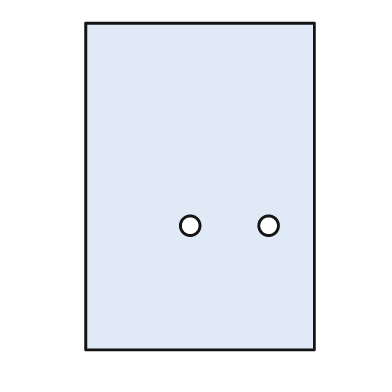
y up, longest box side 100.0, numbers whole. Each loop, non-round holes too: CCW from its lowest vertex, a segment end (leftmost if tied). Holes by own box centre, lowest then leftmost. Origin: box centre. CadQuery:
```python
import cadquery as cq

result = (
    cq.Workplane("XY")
    .moveTo(-35.0, -50.0)
    .lineTo(35.0, -50.0)
    .lineTo(35.0, 50.0)
    .lineTo(-35.0, 50.0)
    .close()
    .moveTo(-3.0, -12.0)
    .circle(3.0)
    .moveTo(21.0, -12.0)
    .circle(3.0)
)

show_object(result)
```